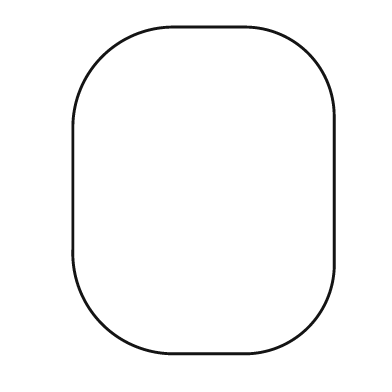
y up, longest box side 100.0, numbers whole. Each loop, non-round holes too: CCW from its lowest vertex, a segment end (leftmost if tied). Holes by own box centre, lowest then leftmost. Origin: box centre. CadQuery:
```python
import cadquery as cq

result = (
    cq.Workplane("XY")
    .moveTo(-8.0, -50.0)
    .lineTo(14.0, -50.0)
    .threePointArc((32.0, -42.0), (40.0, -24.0))
    .lineTo(40.0, 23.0)
    .threePointArc((32.0, 42.0), (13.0, 50.0))
    .lineTo(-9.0, 50.0)
    .threePointArc((-31.0, 41.0), (-40.0, 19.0))
    .lineTo(-40.0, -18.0)
    .threePointArc((-31.0, -41.0), (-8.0, -50.0))
    .close()
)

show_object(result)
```